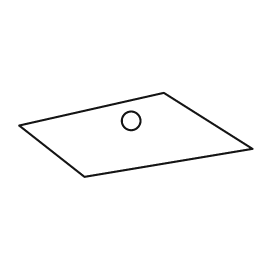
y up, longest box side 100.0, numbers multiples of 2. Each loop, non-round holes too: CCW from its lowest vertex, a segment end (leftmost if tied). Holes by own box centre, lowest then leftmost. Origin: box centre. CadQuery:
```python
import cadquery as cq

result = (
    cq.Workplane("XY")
    .moveTo(-22.0, -18.0)
    .lineTo(50.0, -6.0)
    .lineTo(12.0, 18.0)
    .lineTo(-50.0, 4.0)
    .close()
    .moveTo(-2.0, 6.0)
    .circle(4.0)
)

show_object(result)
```